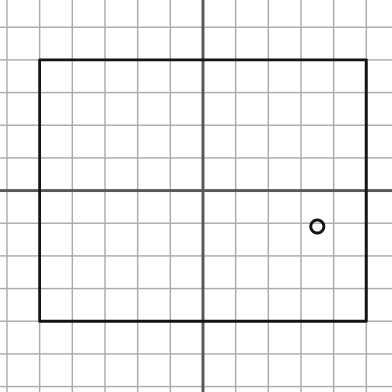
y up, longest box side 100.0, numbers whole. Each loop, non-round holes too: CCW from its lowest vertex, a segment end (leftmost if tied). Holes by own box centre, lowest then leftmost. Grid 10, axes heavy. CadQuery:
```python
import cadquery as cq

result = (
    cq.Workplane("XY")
    .moveTo(-50.0, -40.0)
    .lineTo(50.0, -40.0)
    .lineTo(50.0, 40.0)
    .lineTo(-50.0, 40.0)
    .close()
    .moveTo(35.0, -11.0)
    .circle(2.0)
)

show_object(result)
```